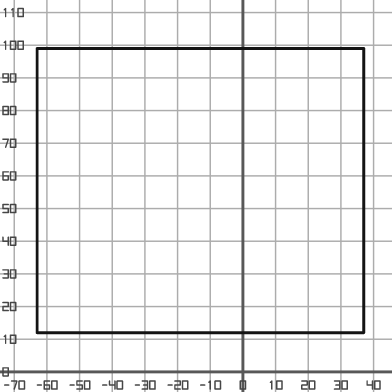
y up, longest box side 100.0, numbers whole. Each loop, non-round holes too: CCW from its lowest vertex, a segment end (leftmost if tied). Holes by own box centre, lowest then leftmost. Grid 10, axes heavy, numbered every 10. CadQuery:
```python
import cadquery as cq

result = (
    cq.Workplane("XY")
    .moveTo(-63.0, 12.0)
    .lineTo(37.0, 12.0)
    .lineTo(37.0, 99.0)
    .lineTo(-63.0, 99.0)
    .close()
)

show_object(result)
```